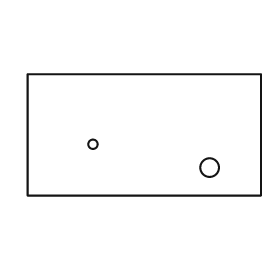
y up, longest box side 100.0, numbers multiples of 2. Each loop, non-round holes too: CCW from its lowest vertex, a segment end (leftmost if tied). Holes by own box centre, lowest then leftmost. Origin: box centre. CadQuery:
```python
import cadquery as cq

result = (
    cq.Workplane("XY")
    .moveTo(-50.0, -26.0)
    .lineTo(50.0, -26.0)
    .lineTo(50.0, 26.0)
    .lineTo(-50.0, 26.0)
    .close()
    .moveTo(28.0, -14.0)
    .circle(4.0)
    .moveTo(-22.0, -4.0)
    .circle(2.0)
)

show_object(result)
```